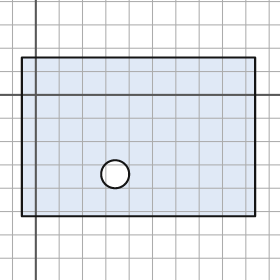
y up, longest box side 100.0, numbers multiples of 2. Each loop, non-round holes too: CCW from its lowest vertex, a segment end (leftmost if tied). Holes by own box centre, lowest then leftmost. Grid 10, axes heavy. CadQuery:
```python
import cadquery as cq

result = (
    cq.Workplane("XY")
    .moveTo(-6.0, -52.0)
    .lineTo(94.0, -52.0)
    .lineTo(94.0, 16.0)
    .lineTo(-6.0, 16.0)
    .close()
    .moveTo(34.0, -34.0)
    .circle(6.0)
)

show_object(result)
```